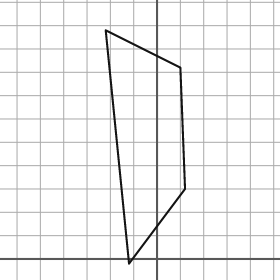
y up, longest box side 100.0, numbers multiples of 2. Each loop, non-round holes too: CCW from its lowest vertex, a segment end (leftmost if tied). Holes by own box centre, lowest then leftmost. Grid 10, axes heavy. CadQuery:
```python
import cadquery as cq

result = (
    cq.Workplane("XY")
    .moveTo(-12.0, -2.0)
    .lineTo(12.0, 30.0)
    .lineTo(10.0, 82.0)
    .lineTo(-22.0, 98.0)
    .close()
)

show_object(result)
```